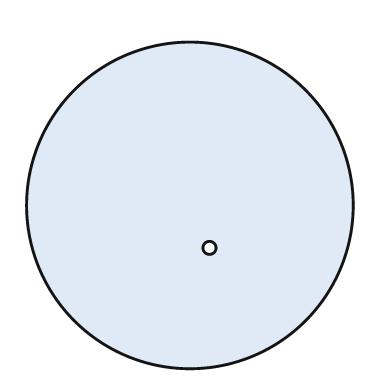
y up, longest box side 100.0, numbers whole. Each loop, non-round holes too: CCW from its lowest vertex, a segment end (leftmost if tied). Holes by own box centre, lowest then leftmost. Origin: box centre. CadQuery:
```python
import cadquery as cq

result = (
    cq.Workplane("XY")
    .moveTo(0.0, 0.0)
    .circle(50.0)
    .moveTo(6.0, -13.0)
    .circle(2.0)
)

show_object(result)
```